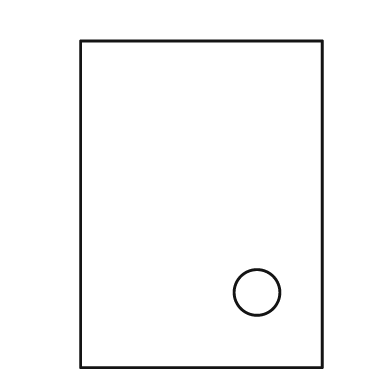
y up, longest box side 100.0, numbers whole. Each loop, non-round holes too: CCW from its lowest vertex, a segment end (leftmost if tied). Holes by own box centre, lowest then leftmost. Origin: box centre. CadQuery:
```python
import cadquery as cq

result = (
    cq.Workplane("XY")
    .moveTo(-37.0, -50.0)
    .lineTo(37.0, -50.0)
    .lineTo(37.0, 50.0)
    .lineTo(-37.0, 50.0)
    .close()
    .moveTo(17.0, -27.0)
    .circle(7.0)
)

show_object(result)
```